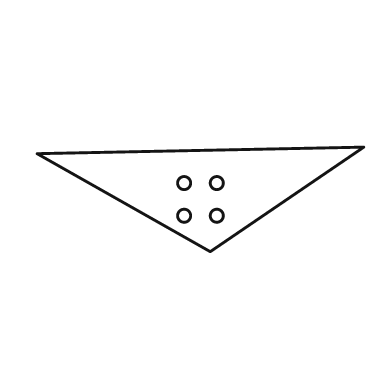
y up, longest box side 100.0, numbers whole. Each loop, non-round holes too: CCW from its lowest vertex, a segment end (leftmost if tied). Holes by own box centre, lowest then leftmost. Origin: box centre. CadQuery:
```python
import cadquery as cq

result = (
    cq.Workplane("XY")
    .moveTo(3.0, -16.0)
    .lineTo(50.0, 16.0)
    .lineTo(-50.0, 14.0)
    .close()
    .moveTo(-5.0, -5.0)
    .circle(2.0)
    .moveTo(5.0, -5.0)
    .circle(2.0)
    .moveTo(-5.0, 5.0)
    .circle(2.0)
    .moveTo(5.0, 5.0)
    .circle(2.0)
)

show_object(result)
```